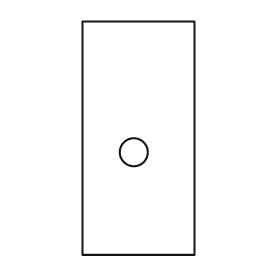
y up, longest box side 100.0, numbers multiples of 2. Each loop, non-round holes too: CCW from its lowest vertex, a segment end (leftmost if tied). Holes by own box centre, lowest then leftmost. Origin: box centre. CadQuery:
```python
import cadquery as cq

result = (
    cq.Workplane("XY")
    .moveTo(-24.0, -50.0)
    .lineTo(24.0, -50.0)
    .lineTo(24.0, 50.0)
    .lineTo(-24.0, 50.0)
    .close()
    .moveTo(-2.0, -6.0)
    .circle(6.0)
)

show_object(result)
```